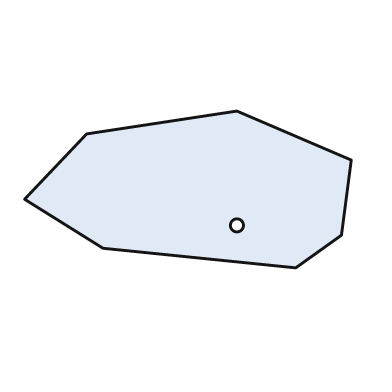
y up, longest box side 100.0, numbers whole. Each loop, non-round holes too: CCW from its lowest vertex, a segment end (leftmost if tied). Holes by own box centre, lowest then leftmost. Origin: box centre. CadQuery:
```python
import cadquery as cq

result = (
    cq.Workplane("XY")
    .moveTo(33.0, -24.0)
    .lineTo(47.0, -14.0)
    .lineTo(50.0, 9.0)
    .lineTo(15.0, 24.0)
    .lineTo(-31.0, 17.0)
    .lineTo(-50.0, -3.0)
    .lineTo(-26.0, -18.0)
    .close()
    .moveTo(15.0, -11.0)
    .circle(2.0)
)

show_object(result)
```